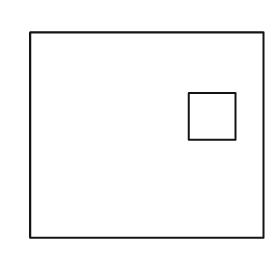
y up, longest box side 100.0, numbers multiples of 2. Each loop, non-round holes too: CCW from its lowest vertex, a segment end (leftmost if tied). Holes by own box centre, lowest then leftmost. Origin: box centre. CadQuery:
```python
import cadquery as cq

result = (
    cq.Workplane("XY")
    .moveTo(-50.0, -44.0)
    .lineTo(50.0, -44.0)
    .lineTo(50.0, 44.0)
    .lineTo(-50.0, 44.0)
    .close()
    .moveTo(18.0, -2.0)
    .lineTo(38.0, -2.0)
    .lineTo(38.0, 18.0)
    .lineTo(18.0, 18.0)
    .close()
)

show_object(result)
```